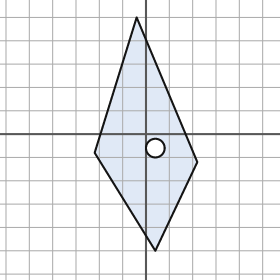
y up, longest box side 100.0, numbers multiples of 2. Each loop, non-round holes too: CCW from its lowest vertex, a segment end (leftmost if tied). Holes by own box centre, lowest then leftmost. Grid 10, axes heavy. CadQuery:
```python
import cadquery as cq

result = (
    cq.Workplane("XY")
    .moveTo(4.0, -50.0)
    .lineTo(22.0, -12.0)
    .lineTo(-4.0, 50.0)
    .lineTo(-22.0, -8.0)
    .close()
    .moveTo(4.0, -6.0)
    .circle(4.0)
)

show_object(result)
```